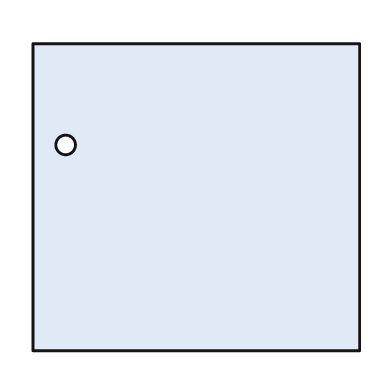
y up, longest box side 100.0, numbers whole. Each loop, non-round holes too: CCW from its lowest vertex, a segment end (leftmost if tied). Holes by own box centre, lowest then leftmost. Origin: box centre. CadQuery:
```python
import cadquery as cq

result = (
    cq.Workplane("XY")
    .moveTo(-50.0, -47.0)
    .lineTo(50.0, -47.0)
    .lineTo(50.0, 47.0)
    .lineTo(-50.0, 47.0)
    .close()
    .moveTo(-40.0, 16.0)
    .circle(3.0)
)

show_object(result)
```